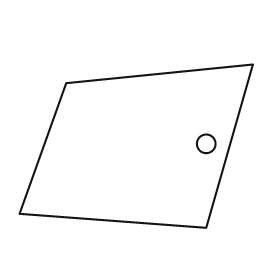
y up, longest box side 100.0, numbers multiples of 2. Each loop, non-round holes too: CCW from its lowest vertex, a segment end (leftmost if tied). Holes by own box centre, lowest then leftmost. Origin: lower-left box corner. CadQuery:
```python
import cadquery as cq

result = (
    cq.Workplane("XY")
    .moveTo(80.0, 0.0)
    .lineTo(100.0, 70.0)
    .lineTo(20.0, 62.0)
    .lineTo(0.0, 6.0)
    .close()
    .moveTo(80.0, 36.0)
    .circle(4.0)
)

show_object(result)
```